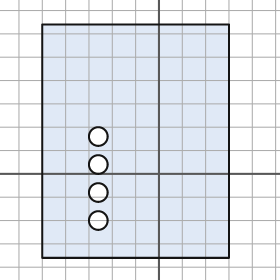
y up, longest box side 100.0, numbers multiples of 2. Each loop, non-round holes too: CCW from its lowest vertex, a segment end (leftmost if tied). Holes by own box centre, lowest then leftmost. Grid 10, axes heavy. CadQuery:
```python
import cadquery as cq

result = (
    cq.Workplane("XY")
    .moveTo(-50.0, -36.0)
    .lineTo(30.0, -36.0)
    .lineTo(30.0, 64.0)
    .lineTo(-50.0, 64.0)
    .close()
    .moveTo(-26.0, -20.0)
    .circle(4.0)
    .moveTo(-26.0, -8.0)
    .circle(4.0)
    .moveTo(-26.0, 4.0)
    .circle(4.0)
    .moveTo(-26.0, 16.0)
    .circle(4.0)
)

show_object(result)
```